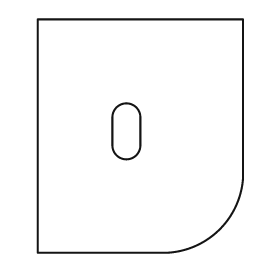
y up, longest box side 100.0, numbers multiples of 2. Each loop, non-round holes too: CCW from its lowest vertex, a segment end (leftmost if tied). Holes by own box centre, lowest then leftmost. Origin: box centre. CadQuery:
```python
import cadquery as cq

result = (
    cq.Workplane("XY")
    .moveTo(-44.0, -50.0)
    .lineTo(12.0, -50.0)
    .threePointArc((34.0, -40.0), (44.0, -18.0))
    .lineTo(44.0, 50.0)
    .lineTo(-44.0, 50.0)
    .close()
    .moveTo(-12.0, -4.0)
    .threePointArc((-6.0, -10.0), (0.0, -4.0))
    .lineTo(0.0, 8.0)
    .threePointArc((-6.0, 14.0), (-12.0, 8.0))
    .close()
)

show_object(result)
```